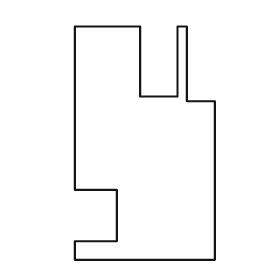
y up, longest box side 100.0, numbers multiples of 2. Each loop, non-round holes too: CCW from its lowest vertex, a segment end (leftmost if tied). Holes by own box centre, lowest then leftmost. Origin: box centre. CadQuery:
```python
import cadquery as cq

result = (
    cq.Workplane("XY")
    .moveTo(-30.0, -50.0)
    .lineTo(30.0, -50.0)
    .lineTo(30.0, 18.0)
    .lineTo(18.0, 18.0)
    .lineTo(18.0, 50.0)
    .lineTo(14.0, 50.0)
    .lineTo(14.0, 20.0)
    .lineTo(-2.0, 20.0)
    .lineTo(-2.0, 50.0)
    .lineTo(-30.0, 50.0)
    .lineTo(-30.0, -20.0)
    .lineTo(-12.0, -20.0)
    .lineTo(-12.0, -42.0)
    .lineTo(-30.0, -42.0)
    .close()
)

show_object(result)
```